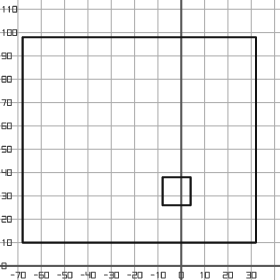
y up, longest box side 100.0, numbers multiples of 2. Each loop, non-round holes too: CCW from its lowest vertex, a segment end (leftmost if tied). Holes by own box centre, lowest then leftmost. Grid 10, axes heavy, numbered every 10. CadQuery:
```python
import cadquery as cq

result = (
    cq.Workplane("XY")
    .moveTo(-68.0, 10.0)
    .lineTo(32.0, 10.0)
    .lineTo(32.0, 98.0)
    .lineTo(-68.0, 98.0)
    .close()
    .moveTo(-8.0, 26.0)
    .lineTo(4.0, 26.0)
    .lineTo(4.0, 38.0)
    .lineTo(-8.0, 38.0)
    .close()
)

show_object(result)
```